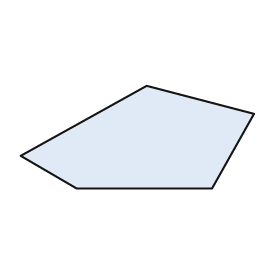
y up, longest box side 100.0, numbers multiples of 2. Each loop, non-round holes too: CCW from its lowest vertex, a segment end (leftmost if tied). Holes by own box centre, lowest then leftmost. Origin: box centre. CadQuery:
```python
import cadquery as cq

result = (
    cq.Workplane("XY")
    .moveTo(-26.0, -22.0)
    .lineTo(32.0, -22.0)
    .lineTo(50.0, 10.0)
    .lineTo(4.0, 22.0)
    .lineTo(-50.0, -8.0)
    .close()
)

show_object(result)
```